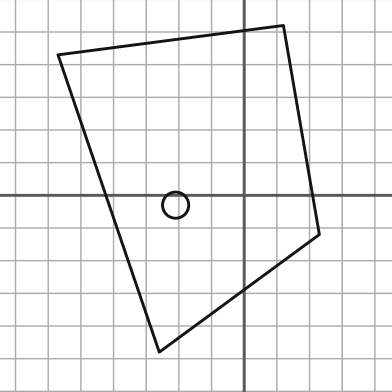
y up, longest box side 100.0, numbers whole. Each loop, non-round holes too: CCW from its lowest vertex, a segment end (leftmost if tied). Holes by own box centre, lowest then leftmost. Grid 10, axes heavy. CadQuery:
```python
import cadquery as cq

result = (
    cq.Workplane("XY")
    .moveTo(-26.0, -48.0)
    .lineTo(23.0, -12.0)
    .lineTo(12.0, 52.0)
    .lineTo(-57.0, 43.0)
    .close()
    .moveTo(-21.0, -3.0)
    .circle(4.0)
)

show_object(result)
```